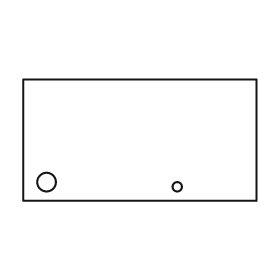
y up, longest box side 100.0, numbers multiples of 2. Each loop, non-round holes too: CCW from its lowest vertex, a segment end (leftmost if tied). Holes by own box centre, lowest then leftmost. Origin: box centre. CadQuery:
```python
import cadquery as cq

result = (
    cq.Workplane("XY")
    .moveTo(-50.0, -26.0)
    .lineTo(50.0, -26.0)
    .lineTo(50.0, 26.0)
    .lineTo(-50.0, 26.0)
    .close()
    .moveTo(16.0, -20.0)
    .circle(2.0)
    .moveTo(-40.0, -18.0)
    .circle(4.0)
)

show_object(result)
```